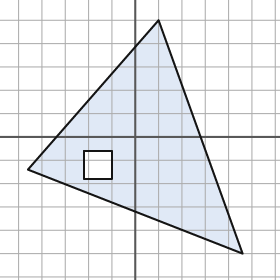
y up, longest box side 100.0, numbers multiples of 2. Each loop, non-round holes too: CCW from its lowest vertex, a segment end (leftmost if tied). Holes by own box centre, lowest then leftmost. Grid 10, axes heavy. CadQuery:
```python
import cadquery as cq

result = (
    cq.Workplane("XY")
    .moveTo(46.0, -50.0)
    .lineTo(10.0, 50.0)
    .lineTo(-46.0, -14.0)
    .close()
    .moveTo(-22.0, -18.0)
    .lineTo(-10.0, -18.0)
    .lineTo(-10.0, -6.0)
    .lineTo(-22.0, -6.0)
    .close()
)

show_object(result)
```